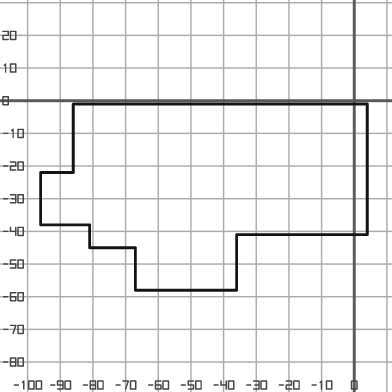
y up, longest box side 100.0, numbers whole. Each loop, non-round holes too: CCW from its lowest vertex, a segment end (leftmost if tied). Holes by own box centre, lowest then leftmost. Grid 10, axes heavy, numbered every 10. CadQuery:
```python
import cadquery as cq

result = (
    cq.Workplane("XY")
    .moveTo(-67.0, -58.0)
    .lineTo(-36.0, -58.0)
    .lineTo(-36.0, -41.0)
    .lineTo(4.0, -41.0)
    .lineTo(4.0, -1.0)
    .lineTo(-86.0, -1.0)
    .lineTo(-86.0, -22.0)
    .lineTo(-96.0, -22.0)
    .lineTo(-96.0, -38.0)
    .lineTo(-81.0, -38.0)
    .lineTo(-81.0, -45.0)
    .lineTo(-67.0, -45.0)
    .close()
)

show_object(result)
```